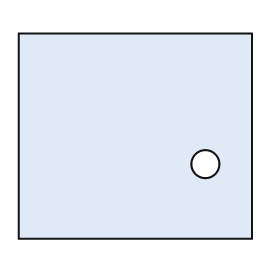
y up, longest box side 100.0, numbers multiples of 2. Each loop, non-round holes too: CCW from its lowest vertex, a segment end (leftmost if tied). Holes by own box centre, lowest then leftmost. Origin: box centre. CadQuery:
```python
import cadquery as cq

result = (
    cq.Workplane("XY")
    .moveTo(-50.0, -44.0)
    .lineTo(50.0, -44.0)
    .lineTo(50.0, 44.0)
    .lineTo(-50.0, 44.0)
    .close()
    .moveTo(30.0, -12.0)
    .circle(6.0)
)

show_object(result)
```